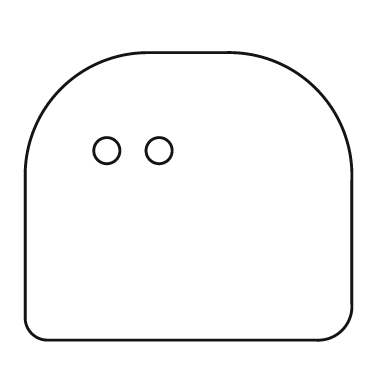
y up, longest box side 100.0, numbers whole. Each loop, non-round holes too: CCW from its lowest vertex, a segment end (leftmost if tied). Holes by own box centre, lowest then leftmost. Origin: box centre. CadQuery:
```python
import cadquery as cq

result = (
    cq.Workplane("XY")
    .moveTo(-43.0, -44.0)
    .lineTo(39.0, -44.0)
    .threePointArc((47.0, -41.0), (50.0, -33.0))
    .lineTo(50.0, 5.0)
    .threePointArc((39.0, 33.0), (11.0, 44.0))
    .lineTo(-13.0, 44.0)
    .threePointArc((-39.0, 33.0), (-50.0, 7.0))
    .lineTo(-50.0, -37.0)
    .threePointArc((-48.0, -42.0), (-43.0, -44.0))
    .close()
    .moveTo(-25.0, 14.0)
    .circle(4.0)
    .moveTo(-9.0, 14.0)
    .circle(4.0)
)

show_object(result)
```